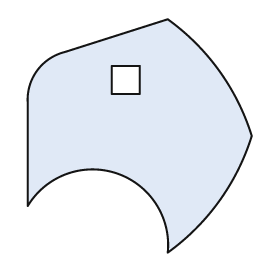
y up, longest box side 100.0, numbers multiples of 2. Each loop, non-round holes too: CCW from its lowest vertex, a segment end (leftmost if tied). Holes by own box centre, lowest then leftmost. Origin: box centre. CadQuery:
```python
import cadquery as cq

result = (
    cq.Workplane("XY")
    .moveTo(12.0, -50.0)
    .threePointArc((34.0, -28.0), (48.0, 0.0))
    .threePointArc((34.0, 28.0), (12.0, 50.0))
    .lineTo(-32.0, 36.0)
    .threePointArc((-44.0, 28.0), (-48.0, 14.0))
    .lineTo(-48.0, -30.0)
    .threePointArc((-10.0, -16.0), (12.0, -50.0))
    .close()
    .moveTo(-12.0, 18.0)
    .lineTo(0.0, 18.0)
    .lineTo(0.0, 30.0)
    .lineTo(-12.0, 30.0)
    .close()
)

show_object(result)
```